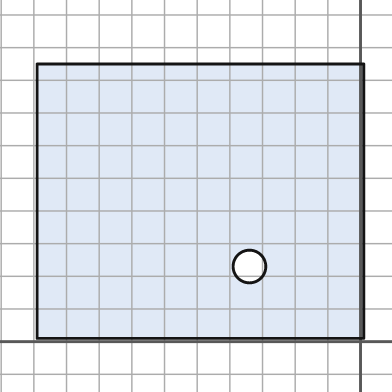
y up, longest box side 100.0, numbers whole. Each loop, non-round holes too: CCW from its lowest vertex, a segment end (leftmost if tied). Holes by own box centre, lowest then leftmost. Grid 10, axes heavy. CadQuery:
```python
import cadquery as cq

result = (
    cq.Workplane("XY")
    .moveTo(-99.0, 1.0)
    .lineTo(1.0, 1.0)
    .lineTo(1.0, 85.0)
    .lineTo(-99.0, 85.0)
    .close()
    .moveTo(-34.0, 23.0)
    .circle(5.0)
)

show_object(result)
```